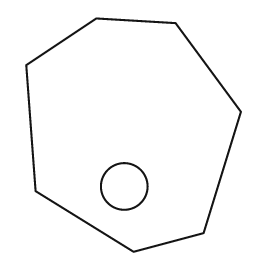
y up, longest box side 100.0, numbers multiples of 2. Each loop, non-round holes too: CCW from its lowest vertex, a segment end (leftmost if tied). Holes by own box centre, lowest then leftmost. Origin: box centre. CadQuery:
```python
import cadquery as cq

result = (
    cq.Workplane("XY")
    .moveTo(0.0, -50.0)
    .lineTo(30.0, -42.0)
    .lineTo(46.0, 10.0)
    .lineTo(18.0, 48.0)
    .lineTo(-16.0, 50.0)
    .lineTo(-46.0, 30.0)
    .lineTo(-42.0, -24.0)
    .close()
    .moveTo(-4.0, -22.0)
    .circle(10.0)
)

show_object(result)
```